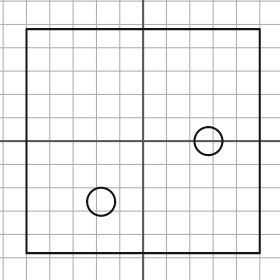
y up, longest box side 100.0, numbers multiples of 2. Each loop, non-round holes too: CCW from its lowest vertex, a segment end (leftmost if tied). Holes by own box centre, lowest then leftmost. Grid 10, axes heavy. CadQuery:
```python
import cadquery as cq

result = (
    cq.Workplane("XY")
    .moveTo(-50.0, -48.0)
    .lineTo(50.0, -48.0)
    .lineTo(50.0, 48.0)
    .lineTo(-50.0, 48.0)
    .close()
    .moveTo(-18.0, -26.0)
    .circle(6.0)
    .moveTo(28.0, 0.0)
    .circle(6.0)
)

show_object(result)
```